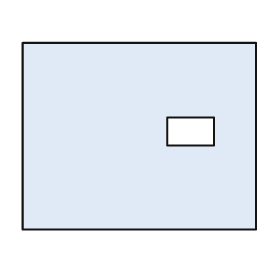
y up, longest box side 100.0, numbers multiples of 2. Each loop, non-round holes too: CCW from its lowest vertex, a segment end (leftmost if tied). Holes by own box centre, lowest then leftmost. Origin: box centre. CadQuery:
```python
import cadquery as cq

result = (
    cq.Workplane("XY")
    .moveTo(-50.0, -40.0)
    .lineTo(50.0, -40.0)
    .lineTo(50.0, 40.0)
    .lineTo(-50.0, 40.0)
    .close()
    .moveTo(12.0, -4.0)
    .lineTo(32.0, -4.0)
    .lineTo(32.0, 8.0)
    .lineTo(12.0, 8.0)
    .close()
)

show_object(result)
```